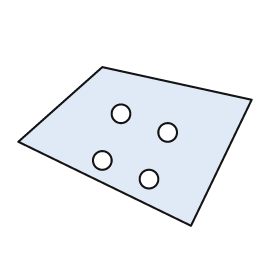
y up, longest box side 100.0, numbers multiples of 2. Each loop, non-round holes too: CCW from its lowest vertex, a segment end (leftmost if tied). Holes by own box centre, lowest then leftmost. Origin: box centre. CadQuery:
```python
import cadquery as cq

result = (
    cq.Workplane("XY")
    .moveTo(24.0, -34.0)
    .lineTo(50.0, 20.0)
    .lineTo(-14.0, 34.0)
    .lineTo(-50.0, 2.0)
    .close()
    .moveTo(6.0, -14.0)
    .circle(4.0)
    .moveTo(-14.0, -6.0)
    .circle(4.0)
    .moveTo(14.0, 6.0)
    .circle(4.0)
    .moveTo(-6.0, 14.0)
    .circle(4.0)
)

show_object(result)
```